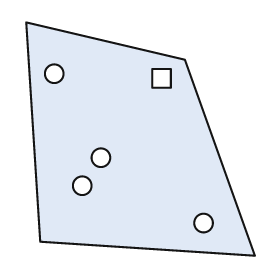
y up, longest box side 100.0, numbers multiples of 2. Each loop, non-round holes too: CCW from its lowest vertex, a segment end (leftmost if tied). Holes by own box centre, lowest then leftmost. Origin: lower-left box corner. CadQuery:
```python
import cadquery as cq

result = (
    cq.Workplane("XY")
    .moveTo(98.0, 0.0)
    .lineTo(68.0, 84.0)
    .lineTo(0.0, 100.0)
    .lineTo(6.0, 6.0)
    .close()
    .moveTo(76.0, 14.0)
    .circle(4.0)
    .moveTo(24.0, 30.0)
    .circle(4.0)
    .moveTo(32.0, 42.0)
    .circle(4.0)
    .moveTo(54.0, 72.0)
    .lineTo(62.0, 72.0)
    .lineTo(62.0, 80.0)
    .lineTo(54.0, 80.0)
    .close()
    .moveTo(12.0, 78.0)
    .circle(4.0)
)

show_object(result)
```